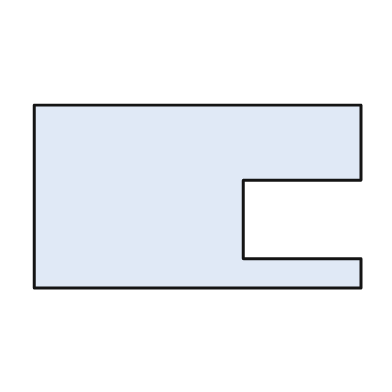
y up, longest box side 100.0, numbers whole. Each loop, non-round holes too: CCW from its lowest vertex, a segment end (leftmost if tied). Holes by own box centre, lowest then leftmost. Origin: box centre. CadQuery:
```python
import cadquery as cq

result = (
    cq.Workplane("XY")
    .moveTo(-50.0, -28.0)
    .lineTo(50.0, -28.0)
    .lineTo(50.0, -19.0)
    .lineTo(14.0, -19.0)
    .lineTo(14.0, 5.0)
    .lineTo(50.0, 5.0)
    .lineTo(50.0, 28.0)
    .lineTo(-50.0, 28.0)
    .close()
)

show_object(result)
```